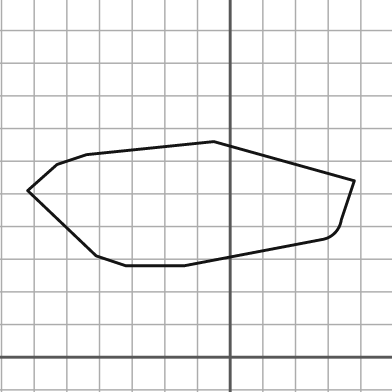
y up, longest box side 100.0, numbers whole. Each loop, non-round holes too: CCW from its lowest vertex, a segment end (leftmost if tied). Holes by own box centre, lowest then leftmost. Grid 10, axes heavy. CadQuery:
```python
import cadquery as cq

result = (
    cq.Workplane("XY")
    .moveTo(-32.0, 28.0)
    .lineTo(-14.0, 28.0)
    .lineTo(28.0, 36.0)
    .threePointArc((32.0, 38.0), (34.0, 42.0))
    .lineTo(38.0, 54.0)
    .lineTo(-5.0, 66.0)
    .lineTo(-44.0, 62.0)
    .lineTo(-53.0, 59.0)
    .lineTo(-62.0, 51.0)
    .lineTo(-41.0, 31.0)
    .close()
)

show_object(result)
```